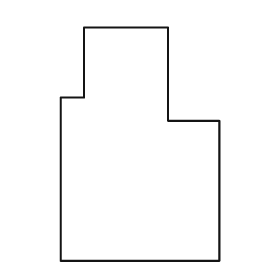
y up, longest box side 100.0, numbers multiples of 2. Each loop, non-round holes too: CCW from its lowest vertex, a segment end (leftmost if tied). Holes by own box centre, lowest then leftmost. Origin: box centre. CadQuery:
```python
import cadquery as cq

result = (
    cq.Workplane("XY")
    .moveTo(-34.0, -50.0)
    .lineTo(34.0, -50.0)
    .lineTo(34.0, 10.0)
    .lineTo(12.0, 10.0)
    .lineTo(12.0, 50.0)
    .lineTo(-24.0, 50.0)
    .lineTo(-24.0, 20.0)
    .lineTo(-34.0, 20.0)
    .close()
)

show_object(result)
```